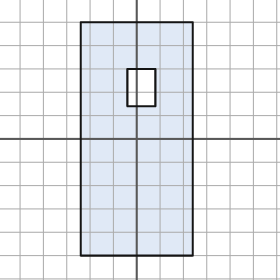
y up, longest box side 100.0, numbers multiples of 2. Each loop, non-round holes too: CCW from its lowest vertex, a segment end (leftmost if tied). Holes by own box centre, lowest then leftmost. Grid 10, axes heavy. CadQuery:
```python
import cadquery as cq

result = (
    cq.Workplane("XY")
    .moveTo(-24.0, -50.0)
    .lineTo(24.0, -50.0)
    .lineTo(24.0, 50.0)
    .lineTo(-24.0, 50.0)
    .close()
    .moveTo(-4.0, 14.0)
    .lineTo(8.0, 14.0)
    .lineTo(8.0, 30.0)
    .lineTo(-4.0, 30.0)
    .close()
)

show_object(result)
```